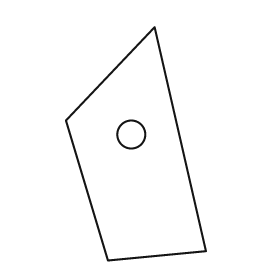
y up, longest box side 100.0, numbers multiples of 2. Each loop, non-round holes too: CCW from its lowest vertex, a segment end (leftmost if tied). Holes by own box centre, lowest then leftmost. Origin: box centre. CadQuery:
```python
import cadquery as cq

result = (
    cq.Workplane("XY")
    .moveTo(-12.0, -50.0)
    .lineTo(30.0, -46.0)
    .lineTo(8.0, 50.0)
    .lineTo(-30.0, 10.0)
    .close()
    .moveTo(-2.0, 4.0)
    .circle(6.0)
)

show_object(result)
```